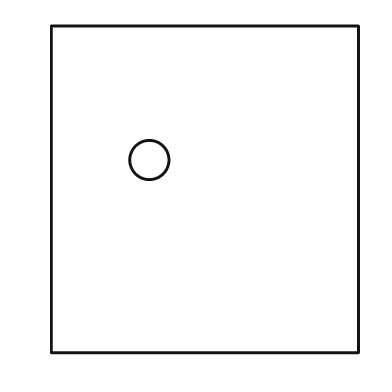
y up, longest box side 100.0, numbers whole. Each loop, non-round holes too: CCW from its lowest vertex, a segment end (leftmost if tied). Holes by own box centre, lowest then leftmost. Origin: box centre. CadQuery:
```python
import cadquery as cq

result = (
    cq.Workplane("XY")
    .moveTo(-47.0, -50.0)
    .lineTo(47.0, -50.0)
    .lineTo(47.0, 50.0)
    .lineTo(-47.0, 50.0)
    .close()
    .moveTo(-17.0, 9.0)
    .circle(6.0)
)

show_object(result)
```